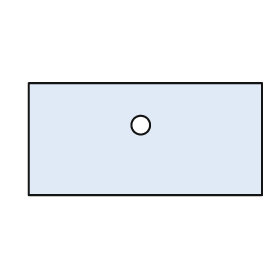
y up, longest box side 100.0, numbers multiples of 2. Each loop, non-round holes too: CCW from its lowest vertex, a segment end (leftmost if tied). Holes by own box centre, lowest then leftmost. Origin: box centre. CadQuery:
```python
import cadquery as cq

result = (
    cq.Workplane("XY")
    .moveTo(-50.0, -24.0)
    .lineTo(50.0, -24.0)
    .lineTo(50.0, 24.0)
    .lineTo(-50.0, 24.0)
    .close()
    .moveTo(-2.0, 6.0)
    .circle(4.0)
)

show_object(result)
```